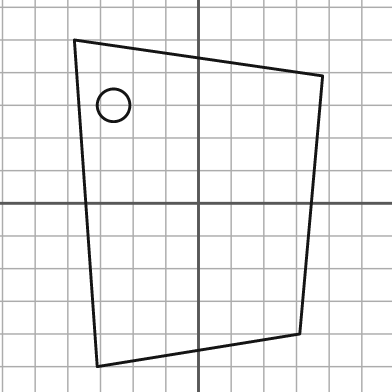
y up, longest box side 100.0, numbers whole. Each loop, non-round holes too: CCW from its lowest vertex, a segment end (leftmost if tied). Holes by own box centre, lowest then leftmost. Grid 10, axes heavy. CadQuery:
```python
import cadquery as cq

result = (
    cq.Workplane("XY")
    .moveTo(-31.0, -50.0)
    .lineTo(31.0, -40.0)
    .lineTo(38.0, 39.0)
    .lineTo(-38.0, 50.0)
    .close()
    .moveTo(-26.0, 30.0)
    .circle(5.0)
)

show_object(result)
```